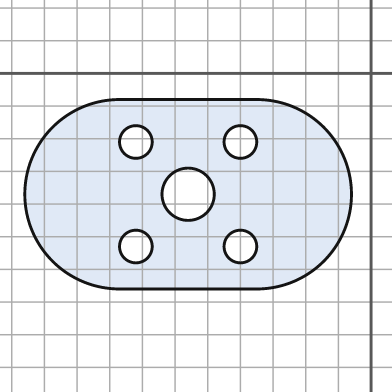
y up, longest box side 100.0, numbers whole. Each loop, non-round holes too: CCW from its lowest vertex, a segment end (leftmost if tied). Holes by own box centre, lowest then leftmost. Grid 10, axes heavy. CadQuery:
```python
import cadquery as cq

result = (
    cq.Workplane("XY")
    .moveTo(-77.0, -66.0)
    .lineTo(-35.0, -66.0)
    .threePointArc((-6.0, -37.0), (-35.0, -8.0))
    .lineTo(-77.0, -8.0)
    .threePointArc((-106.0, -37.0), (-77.0, -66.0))
    .close()
    .moveTo(-72.0, -53.0)
    .circle(5.0)
    .moveTo(-40.0, -53.0)
    .circle(5.0)
    .moveTo(-56.0, -37.0)
    .circle(8.0)
    .moveTo(-72.0, -21.0)
    .circle(5.0)
    .moveTo(-40.0, -21.0)
    .circle(5.0)
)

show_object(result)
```